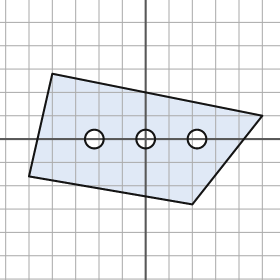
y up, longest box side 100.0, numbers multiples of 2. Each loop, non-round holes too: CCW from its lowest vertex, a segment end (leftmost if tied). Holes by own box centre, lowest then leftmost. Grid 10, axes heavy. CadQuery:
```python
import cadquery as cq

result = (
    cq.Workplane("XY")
    .moveTo(20.0, -28.0)
    .lineTo(50.0, 10.0)
    .lineTo(-40.0, 28.0)
    .lineTo(-50.0, -16.0)
    .close()
    .moveTo(-22.0, 0.0)
    .circle(4.0)
    .moveTo(0.0, 0.0)
    .circle(4.0)
    .moveTo(22.0, 0.0)
    .circle(4.0)
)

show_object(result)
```